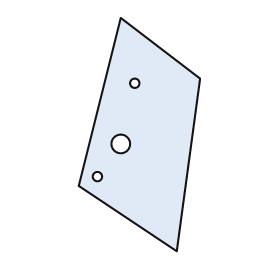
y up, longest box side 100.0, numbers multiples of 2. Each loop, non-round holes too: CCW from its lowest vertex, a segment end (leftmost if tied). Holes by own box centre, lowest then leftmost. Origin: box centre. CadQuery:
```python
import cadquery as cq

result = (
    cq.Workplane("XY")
    .moveTo(16.0, -50.0)
    .lineTo(26.0, 24.0)
    .lineTo(-8.0, 50.0)
    .lineTo(-26.0, -22.0)
    .close()
    .moveTo(-18.0, -18.0)
    .circle(2.0)
    .moveTo(-8.0, -4.0)
    .circle(4.0)
    .moveTo(-2.0, 22.0)
    .circle(2.0)
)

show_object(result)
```